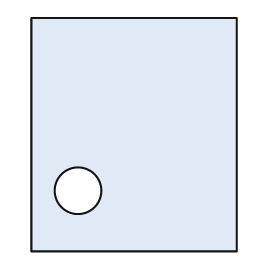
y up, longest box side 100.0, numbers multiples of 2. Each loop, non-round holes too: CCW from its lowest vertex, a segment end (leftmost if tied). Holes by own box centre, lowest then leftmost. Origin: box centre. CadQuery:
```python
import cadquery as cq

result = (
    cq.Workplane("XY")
    .moveTo(-44.0, -50.0)
    .lineTo(44.0, -50.0)
    .lineTo(44.0, 50.0)
    .lineTo(-44.0, 50.0)
    .close()
    .moveTo(-24.0, -24.0)
    .circle(10.0)
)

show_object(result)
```